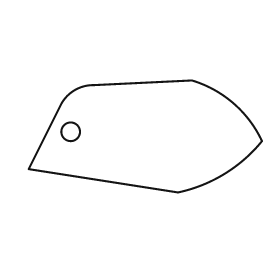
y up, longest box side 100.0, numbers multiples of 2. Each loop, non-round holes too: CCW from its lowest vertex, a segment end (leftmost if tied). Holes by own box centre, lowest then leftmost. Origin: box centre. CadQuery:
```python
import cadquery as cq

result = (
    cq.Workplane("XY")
    .moveTo(14.0, -24.0)
    .threePointArc((34.0, -16.0), (50.0, -2.0))
    .threePointArc((38.0, 14.0), (20.0, 24.0))
    .lineTo(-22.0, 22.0)
    .threePointArc((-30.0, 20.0), (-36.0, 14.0))
    .lineTo(-50.0, -14.0)
    .close()
    .moveTo(-32.0, 2.0)
    .circle(4.0)
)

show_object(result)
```